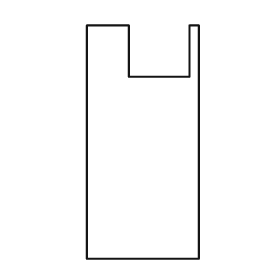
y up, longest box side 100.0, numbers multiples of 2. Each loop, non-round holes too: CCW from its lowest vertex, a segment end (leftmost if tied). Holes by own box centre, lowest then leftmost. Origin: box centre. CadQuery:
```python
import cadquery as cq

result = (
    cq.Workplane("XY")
    .moveTo(-24.0, -50.0)
    .lineTo(24.0, -50.0)
    .lineTo(24.0, 50.0)
    .lineTo(20.0, 50.0)
    .lineTo(20.0, 28.0)
    .lineTo(-6.0, 28.0)
    .lineTo(-6.0, 50.0)
    .lineTo(-24.0, 50.0)
    .close()
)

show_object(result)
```